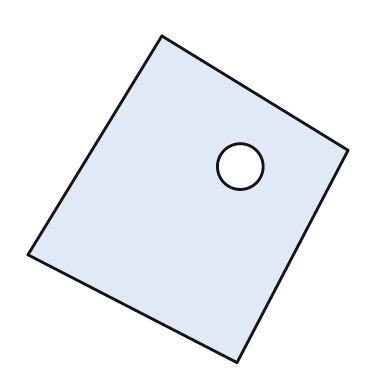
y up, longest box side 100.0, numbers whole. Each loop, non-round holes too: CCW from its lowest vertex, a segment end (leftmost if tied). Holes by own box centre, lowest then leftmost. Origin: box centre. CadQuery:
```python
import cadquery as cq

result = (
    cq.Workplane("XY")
    .moveTo(15.0, -50.0)
    .lineTo(49.0, 15.0)
    .lineTo(-8.0, 50.0)
    .lineTo(-49.0, -17.0)
    .close()
    .moveTo(16.0, 10.0)
    .circle(7.0)
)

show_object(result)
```